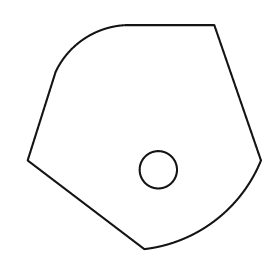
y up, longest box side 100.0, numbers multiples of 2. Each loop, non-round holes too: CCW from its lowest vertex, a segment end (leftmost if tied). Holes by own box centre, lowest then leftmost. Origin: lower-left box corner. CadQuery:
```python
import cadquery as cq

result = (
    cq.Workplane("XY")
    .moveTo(50.0, 0.0)
    .threePointArc((80.0, 12.0), (100.0, 38.0))
    .lineTo(80.0, 96.0)
    .lineTo(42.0, 96.0)
    .threePointArc((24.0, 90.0), (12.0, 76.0))
    .lineTo(0.0, 38.0)
    .close()
    .moveTo(56.0, 34.0)
    .circle(8.0)
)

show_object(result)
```